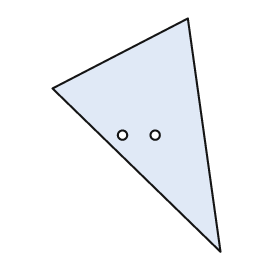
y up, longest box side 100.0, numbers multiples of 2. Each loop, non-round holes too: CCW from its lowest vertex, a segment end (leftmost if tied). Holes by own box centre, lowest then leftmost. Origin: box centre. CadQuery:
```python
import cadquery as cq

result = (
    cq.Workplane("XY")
    .moveTo(36.0, -50.0)
    .lineTo(22.0, 50.0)
    .lineTo(-36.0, 20.0)
    .close()
    .moveTo(-6.0, 0.0)
    .circle(2.0)
    .moveTo(8.0, 0.0)
    .circle(2.0)
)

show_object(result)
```